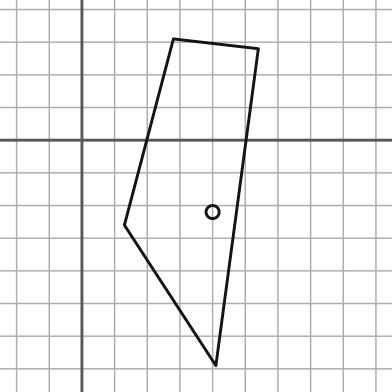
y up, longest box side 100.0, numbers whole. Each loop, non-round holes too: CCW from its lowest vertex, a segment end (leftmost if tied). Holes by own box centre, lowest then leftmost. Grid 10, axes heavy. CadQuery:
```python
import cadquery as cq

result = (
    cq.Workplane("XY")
    .moveTo(41.0, -69.0)
    .lineTo(54.0, 28.0)
    .lineTo(28.0, 31.0)
    .lineTo(13.0, -26.0)
    .close()
    .moveTo(40.0, -22.0)
    .circle(2.0)
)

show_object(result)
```